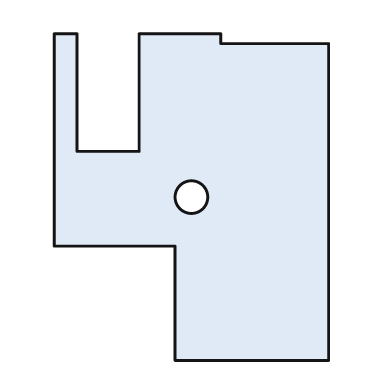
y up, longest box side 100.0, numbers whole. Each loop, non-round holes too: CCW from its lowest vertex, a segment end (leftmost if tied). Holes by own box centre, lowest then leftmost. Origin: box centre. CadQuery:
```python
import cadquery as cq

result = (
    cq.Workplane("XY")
    .moveTo(-5.0, -50.0)
    .lineTo(42.0, -50.0)
    .lineTo(42.0, 47.0)
    .lineTo(9.0, 47.0)
    .lineTo(9.0, 50.0)
    .lineTo(-16.0, 50.0)
    .lineTo(-16.0, 14.0)
    .lineTo(-35.0, 14.0)
    .lineTo(-35.0, 50.0)
    .lineTo(-42.0, 50.0)
    .lineTo(-42.0, -15.0)
    .lineTo(-5.0, -15.0)
    .close()
    .moveTo(0.0, 0.0)
    .circle(5.0)
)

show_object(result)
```